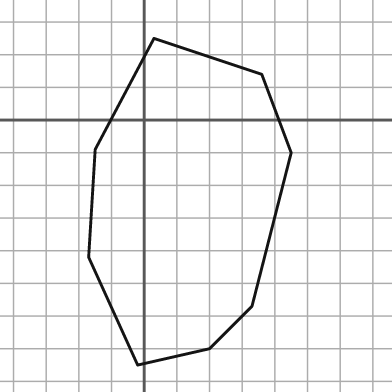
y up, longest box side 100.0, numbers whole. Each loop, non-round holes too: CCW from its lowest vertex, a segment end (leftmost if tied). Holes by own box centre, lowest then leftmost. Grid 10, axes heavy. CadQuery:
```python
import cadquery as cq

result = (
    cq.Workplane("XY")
    .moveTo(-2.0, -75.0)
    .lineTo(20.0, -70.0)
    .lineTo(33.0, -57.0)
    .lineTo(45.0, -10.0)
    .lineTo(36.0, 14.0)
    .lineTo(3.0, 25.0)
    .lineTo(-15.0, -9.0)
    .lineTo(-17.0, -42.0)
    .close()
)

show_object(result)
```